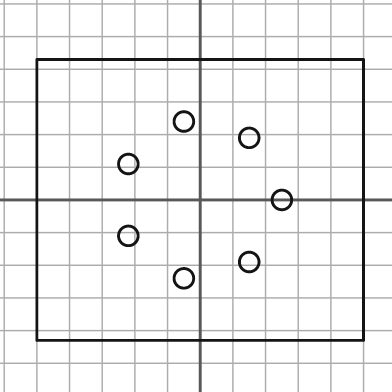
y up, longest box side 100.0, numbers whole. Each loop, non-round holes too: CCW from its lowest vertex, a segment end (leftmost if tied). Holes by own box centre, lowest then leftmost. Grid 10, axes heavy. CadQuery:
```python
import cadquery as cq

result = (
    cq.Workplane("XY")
    .moveTo(-50.0, -43.0)
    .lineTo(50.0, -43.0)
    .lineTo(50.0, 43.0)
    .lineTo(-50.0, 43.0)
    .close()
    .moveTo(-5.0, -24.0)
    .circle(3.0)
    .moveTo(15.0, -19.0)
    .circle(3.0)
    .moveTo(-22.0, -11.0)
    .circle(3.0)
    .moveTo(25.0, 0.0)
    .circle(3.0)
    .moveTo(-22.0, 11.0)
    .circle(3.0)
    .moveTo(15.0, 19.0)
    .circle(3.0)
    .moveTo(-5.0, 24.0)
    .circle(3.0)
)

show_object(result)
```